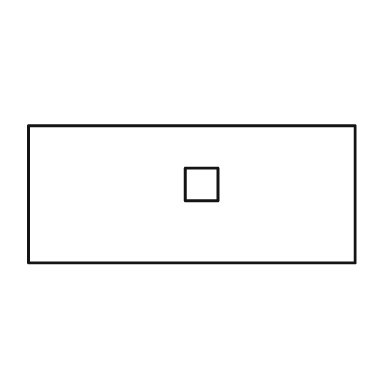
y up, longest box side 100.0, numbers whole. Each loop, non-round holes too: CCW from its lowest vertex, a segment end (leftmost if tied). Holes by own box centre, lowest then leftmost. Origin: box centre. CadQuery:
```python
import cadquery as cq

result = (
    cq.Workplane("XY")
    .moveTo(-50.0, -21.0)
    .lineTo(50.0, -21.0)
    .lineTo(50.0, 21.0)
    .lineTo(-50.0, 21.0)
    .close()
    .moveTo(-2.0, -2.0)
    .lineTo(8.0, -2.0)
    .lineTo(8.0, 8.0)
    .lineTo(-2.0, 8.0)
    .close()
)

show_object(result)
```